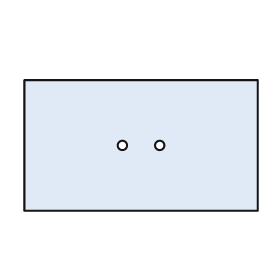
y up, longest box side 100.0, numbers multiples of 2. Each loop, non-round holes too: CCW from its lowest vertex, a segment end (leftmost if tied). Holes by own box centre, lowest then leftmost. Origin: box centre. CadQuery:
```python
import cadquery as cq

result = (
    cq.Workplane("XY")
    .moveTo(-50.0, -28.0)
    .lineTo(50.0, -28.0)
    .lineTo(50.0, 28.0)
    .lineTo(-50.0, 28.0)
    .close()
    .moveTo(-8.0, 0.0)
    .circle(2.0)
    .moveTo(8.0, 0.0)
    .circle(2.0)
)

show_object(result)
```